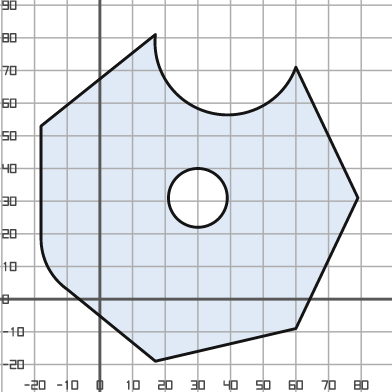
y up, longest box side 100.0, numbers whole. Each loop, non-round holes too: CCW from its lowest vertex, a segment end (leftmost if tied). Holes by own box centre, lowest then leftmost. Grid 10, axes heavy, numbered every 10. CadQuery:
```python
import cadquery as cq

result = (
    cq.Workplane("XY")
    .moveTo(17.0, -19.0)
    .lineTo(60.0, -9.0)
    .lineTo(79.0, 31.0)
    .lineTo(60.0, 71.0)
    .threePointArc((34.0, 57.0), (17.0, 81.0))
    .lineTo(-18.0, 53.0)
    .lineTo(-18.0, 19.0)
    .threePointArc((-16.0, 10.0), (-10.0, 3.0))
    .close()
    .moveTo(30.0, 31.0)
    .circle(9.0)
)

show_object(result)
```